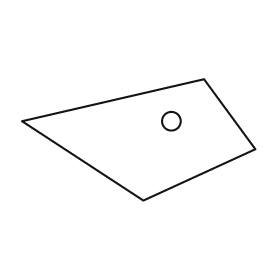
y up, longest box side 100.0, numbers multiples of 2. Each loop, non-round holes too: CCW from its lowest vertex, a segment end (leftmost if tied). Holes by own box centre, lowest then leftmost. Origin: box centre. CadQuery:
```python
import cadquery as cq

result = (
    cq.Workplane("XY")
    .moveTo(2.0, -26.0)
    .lineTo(50.0, -4.0)
    .lineTo(28.0, 26.0)
    .lineTo(-50.0, 8.0)
    .close()
    .moveTo(14.0, 8.0)
    .circle(4.0)
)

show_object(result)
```